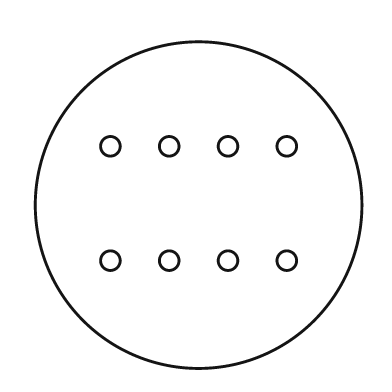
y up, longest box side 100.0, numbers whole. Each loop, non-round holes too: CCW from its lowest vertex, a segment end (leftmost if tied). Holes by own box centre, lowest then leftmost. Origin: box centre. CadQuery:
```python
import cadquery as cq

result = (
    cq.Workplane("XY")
    .moveTo(0.0, 0.0)
    .circle(50.0)
    .moveTo(-27.0, -17.0)
    .circle(3.0)
    .moveTo(-9.0, -17.0)
    .circle(3.0)
    .moveTo(9.0, -17.0)
    .circle(3.0)
    .moveTo(27.0, -17.0)
    .circle(3.0)
    .moveTo(-27.0, 18.0)
    .circle(3.0)
    .moveTo(-9.0, 18.0)
    .circle(3.0)
    .moveTo(9.0, 18.0)
    .circle(3.0)
    .moveTo(27.0, 18.0)
    .circle(3.0)
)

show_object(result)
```